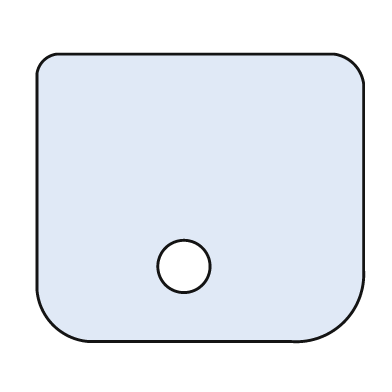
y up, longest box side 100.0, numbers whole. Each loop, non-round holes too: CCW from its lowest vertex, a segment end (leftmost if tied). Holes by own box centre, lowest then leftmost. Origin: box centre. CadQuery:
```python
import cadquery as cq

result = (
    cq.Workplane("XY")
    .moveTo(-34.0, -44.0)
    .lineTo(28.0, -44.0)
    .threePointArc((44.0, -38.0), (50.0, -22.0))
    .lineTo(50.0, 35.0)
    .threePointArc((47.0, 41.0), (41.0, 44.0))
    .lineTo(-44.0, 44.0)
    .threePointArc((-48.0, 42.0), (-50.0, 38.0))
    .lineTo(-50.0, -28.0)
    .threePointArc((-45.0, -39.0), (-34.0, -44.0))
    .close()
    .moveTo(-5.0, -21.0)
    .circle(8.0)
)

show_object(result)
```